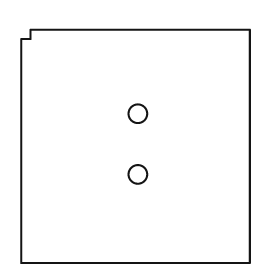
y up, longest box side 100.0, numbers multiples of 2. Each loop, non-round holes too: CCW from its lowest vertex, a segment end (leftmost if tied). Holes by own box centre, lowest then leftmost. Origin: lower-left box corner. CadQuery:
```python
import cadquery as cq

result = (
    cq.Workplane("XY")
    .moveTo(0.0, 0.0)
    .lineTo(98.0, 0.0)
    .lineTo(98.0, 100.0)
    .lineTo(4.0, 100.0)
    .lineTo(4.0, 96.0)
    .lineTo(0.0, 96.0)
    .close()
    .moveTo(50.0, 38.0)
    .circle(4.0)
    .moveTo(50.0, 64.0)
    .circle(4.0)
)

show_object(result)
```